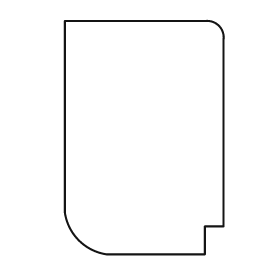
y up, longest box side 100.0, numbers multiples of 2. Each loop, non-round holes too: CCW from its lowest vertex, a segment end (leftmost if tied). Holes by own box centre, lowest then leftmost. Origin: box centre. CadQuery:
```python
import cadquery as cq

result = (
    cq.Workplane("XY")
    .moveTo(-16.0, -50.0)
    .lineTo(26.0, -50.0)
    .lineTo(26.0, -38.0)
    .lineTo(34.0, -38.0)
    .lineTo(34.0, 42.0)
    .threePointArc((32.0, 48.0), (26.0, 50.0))
    .lineTo(-34.0, 50.0)
    .lineTo(-34.0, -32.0)
    .threePointArc((-28.0, -44.0), (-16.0, -50.0))
    .close()
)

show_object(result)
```